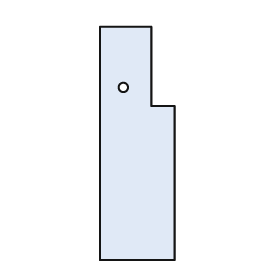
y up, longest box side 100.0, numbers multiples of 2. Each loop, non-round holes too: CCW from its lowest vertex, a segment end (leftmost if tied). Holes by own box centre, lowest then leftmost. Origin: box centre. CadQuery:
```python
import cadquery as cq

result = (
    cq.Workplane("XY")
    .moveTo(-16.0, -50.0)
    .lineTo(16.0, -50.0)
    .lineTo(16.0, 16.0)
    .lineTo(6.0, 16.0)
    .lineTo(6.0, 50.0)
    .lineTo(-16.0, 50.0)
    .close()
    .moveTo(-6.0, 24.0)
    .circle(2.0)
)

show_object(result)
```